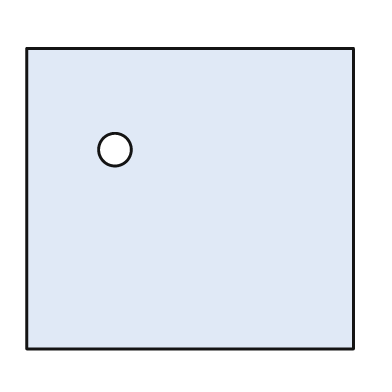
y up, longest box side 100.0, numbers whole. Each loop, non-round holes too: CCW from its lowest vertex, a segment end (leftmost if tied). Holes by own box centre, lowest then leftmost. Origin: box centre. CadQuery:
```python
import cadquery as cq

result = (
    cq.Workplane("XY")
    .moveTo(-50.0, -46.0)
    .lineTo(50.0, -46.0)
    .lineTo(50.0, 46.0)
    .lineTo(-50.0, 46.0)
    .close()
    .moveTo(-23.0, 15.0)
    .circle(5.0)
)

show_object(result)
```